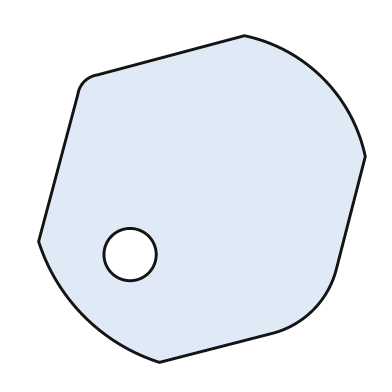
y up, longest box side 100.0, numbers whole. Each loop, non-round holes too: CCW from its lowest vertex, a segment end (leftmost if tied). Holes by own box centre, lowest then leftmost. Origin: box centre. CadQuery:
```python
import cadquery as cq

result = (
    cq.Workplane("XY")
    .moveTo(-13.0, -50.0)
    .lineTo(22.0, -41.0)
    .threePointArc((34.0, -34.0), (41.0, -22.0))
    .lineTo(50.0, 13.0)
    .threePointArc((37.0, 37.0), (13.0, 50.0))
    .lineTo(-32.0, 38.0)
    .threePointArc((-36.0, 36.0), (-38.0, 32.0))
    .lineTo(-50.0, -13.0)
    .threePointArc((-36.0, -36.0), (-13.0, -50.0))
    .close()
    .moveTo(-22.0, -17.0)
    .circle(8.0)
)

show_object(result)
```